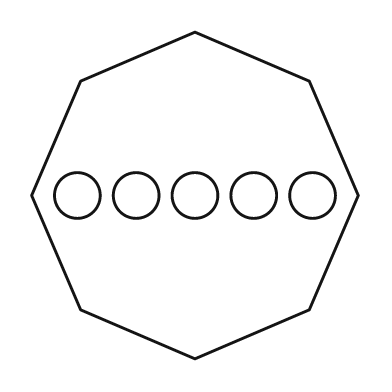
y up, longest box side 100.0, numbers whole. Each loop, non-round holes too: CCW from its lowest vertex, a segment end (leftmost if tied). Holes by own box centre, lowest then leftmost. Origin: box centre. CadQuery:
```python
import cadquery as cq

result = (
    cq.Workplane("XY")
    .moveTo(0.0, -50.0)
    .lineTo(35.0, -35.0)
    .lineTo(50.0, 0.0)
    .lineTo(35.0, 35.0)
    .lineTo(0.0, 50.0)
    .lineTo(-35.0, 35.0)
    .lineTo(-50.0, 0.0)
    .lineTo(-35.0, -35.0)
    .close()
    .moveTo(-36.0, 0.0)
    .circle(7.0)
    .moveTo(-18.0, 0.0)
    .circle(7.0)
    .moveTo(0.0, 0.0)
    .circle(7.0)
    .moveTo(18.0, 0.0)
    .circle(7.0)
    .moveTo(36.0, 0.0)
    .circle(7.0)
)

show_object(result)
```